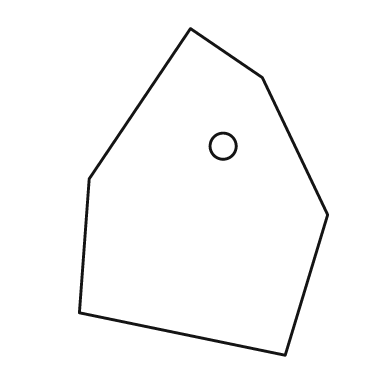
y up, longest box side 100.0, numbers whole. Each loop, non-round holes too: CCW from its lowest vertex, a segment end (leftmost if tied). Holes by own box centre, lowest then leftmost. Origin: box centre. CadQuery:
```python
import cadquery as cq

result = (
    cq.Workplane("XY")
    .moveTo(25.0, -50.0)
    .lineTo(38.0, -7.0)
    .lineTo(18.0, 35.0)
    .lineTo(-4.0, 50.0)
    .lineTo(-35.0, 4.0)
    .lineTo(-38.0, -37.0)
    .close()
    .moveTo(6.0, 14.0)
    .circle(4.0)
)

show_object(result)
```